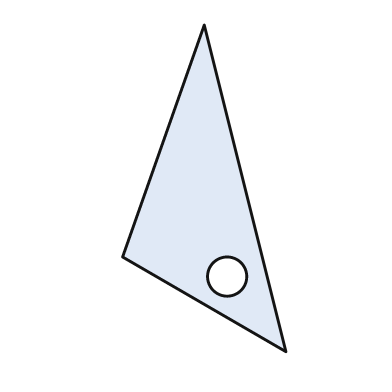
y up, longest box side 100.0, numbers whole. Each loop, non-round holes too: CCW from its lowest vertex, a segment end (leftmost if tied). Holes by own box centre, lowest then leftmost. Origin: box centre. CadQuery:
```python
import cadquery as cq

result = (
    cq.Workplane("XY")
    .moveTo(25.0, -50.0)
    .lineTo(0.0, 50.0)
    .lineTo(-25.0, -21.0)
    .close()
    .moveTo(7.0, -27.0)
    .circle(6.0)
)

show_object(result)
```